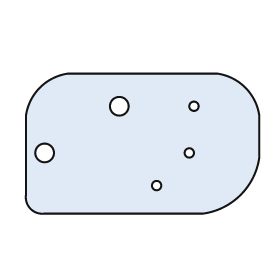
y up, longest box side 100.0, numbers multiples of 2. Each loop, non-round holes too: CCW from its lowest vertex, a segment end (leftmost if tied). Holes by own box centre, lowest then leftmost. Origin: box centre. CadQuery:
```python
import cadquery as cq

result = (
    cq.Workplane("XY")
    .moveTo(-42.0, -30.0)
    .lineTo(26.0, -30.0)
    .threePointArc((42.0, -22.0), (50.0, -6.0))
    .lineTo(50.0, 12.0)
    .threePointArc((44.0, 24.0), (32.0, 30.0))
    .lineTo(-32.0, 30.0)
    .threePointArc((-44.0, 24.0), (-50.0, 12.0))
    .lineTo(-50.0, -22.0)
    .threePointArc((-48.0, -28.0), (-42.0, -30.0))
    .close()
    .moveTo(6.0, -18.0)
    .circle(2.0)
    .moveTo(-42.0, -4.0)
    .circle(4.0)
    .moveTo(20.0, -4.0)
    .circle(2.0)
    .moveTo(-10.0, 16.0)
    .circle(4.0)
    .moveTo(22.0, 16.0)
    .circle(2.0)
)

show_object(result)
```